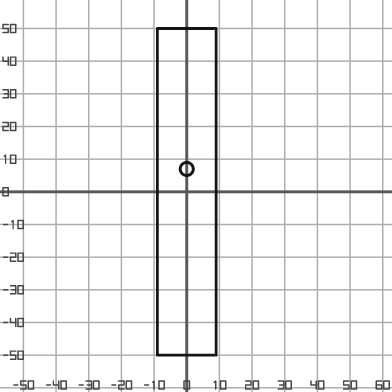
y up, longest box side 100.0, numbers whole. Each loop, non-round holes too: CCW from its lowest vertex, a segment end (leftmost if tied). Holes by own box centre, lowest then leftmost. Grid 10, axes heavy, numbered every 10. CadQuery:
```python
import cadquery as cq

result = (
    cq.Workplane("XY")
    .moveTo(-9.0, -50.0)
    .lineTo(9.0, -50.0)
    .lineTo(9.0, 50.0)
    .lineTo(-9.0, 50.0)
    .close()
    .moveTo(0.0, 7.0)
    .circle(2.0)
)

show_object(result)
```